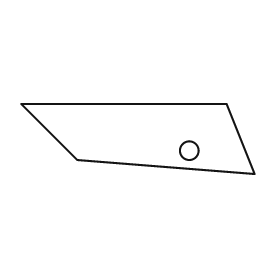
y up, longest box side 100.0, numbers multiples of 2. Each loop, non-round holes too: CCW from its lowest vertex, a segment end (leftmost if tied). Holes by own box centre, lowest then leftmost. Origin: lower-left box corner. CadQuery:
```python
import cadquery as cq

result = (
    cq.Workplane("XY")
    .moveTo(100.0, 0.0)
    .lineTo(88.0, 30.0)
    .lineTo(0.0, 30.0)
    .lineTo(24.0, 6.0)
    .close()
    .moveTo(72.0, 10.0)
    .circle(4.0)
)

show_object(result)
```